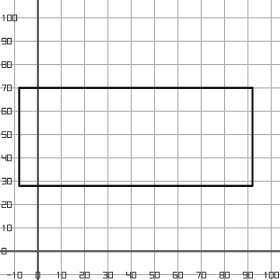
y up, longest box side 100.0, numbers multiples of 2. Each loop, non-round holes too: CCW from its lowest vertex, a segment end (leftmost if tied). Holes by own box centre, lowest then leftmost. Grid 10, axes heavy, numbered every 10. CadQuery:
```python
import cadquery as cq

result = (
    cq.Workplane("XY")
    .moveTo(-8.0, 28.0)
    .lineTo(92.0, 28.0)
    .lineTo(92.0, 70.0)
    .lineTo(-8.0, 70.0)
    .close()
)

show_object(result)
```